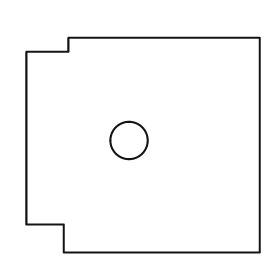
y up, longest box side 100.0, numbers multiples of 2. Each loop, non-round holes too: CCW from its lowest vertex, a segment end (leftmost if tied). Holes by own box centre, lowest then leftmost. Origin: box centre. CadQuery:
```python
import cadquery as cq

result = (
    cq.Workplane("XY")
    .moveTo(-34.0, -46.0)
    .lineTo(50.0, -46.0)
    .lineTo(50.0, 46.0)
    .lineTo(-32.0, 46.0)
    .lineTo(-32.0, 40.0)
    .lineTo(-50.0, 40.0)
    .lineTo(-50.0, -34.0)
    .lineTo(-34.0, -34.0)
    .close()
    .moveTo(-6.0, 2.0)
    .circle(8.0)
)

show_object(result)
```